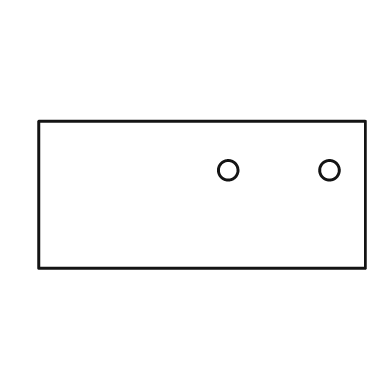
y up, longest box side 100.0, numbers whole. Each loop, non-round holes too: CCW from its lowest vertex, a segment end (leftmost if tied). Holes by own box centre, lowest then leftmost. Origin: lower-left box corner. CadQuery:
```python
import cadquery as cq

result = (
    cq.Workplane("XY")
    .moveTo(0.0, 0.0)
    .lineTo(100.0, 0.0)
    .lineTo(100.0, 45.0)
    .lineTo(0.0, 45.0)
    .close()
    .moveTo(58.0, 30.0)
    .circle(3.0)
    .moveTo(89.0, 30.0)
    .circle(3.0)
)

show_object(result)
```